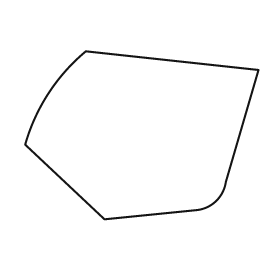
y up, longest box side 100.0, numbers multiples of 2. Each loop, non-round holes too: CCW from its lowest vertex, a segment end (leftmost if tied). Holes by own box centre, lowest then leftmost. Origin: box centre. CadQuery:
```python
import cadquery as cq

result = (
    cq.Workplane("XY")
    .moveTo(-16.0, -36.0)
    .lineTo(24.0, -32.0)
    .threePointArc((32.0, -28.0), (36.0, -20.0))
    .lineTo(50.0, 28.0)
    .lineTo(-24.0, 36.0)
    .threePointArc((-40.0, 18.0), (-50.0, -4.0))
    .close()
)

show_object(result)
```